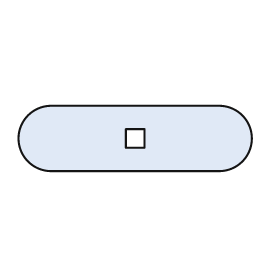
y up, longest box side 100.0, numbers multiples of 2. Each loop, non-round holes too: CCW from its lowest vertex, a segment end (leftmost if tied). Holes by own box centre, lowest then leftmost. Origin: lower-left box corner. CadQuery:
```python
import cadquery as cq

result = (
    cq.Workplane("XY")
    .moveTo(14.0, 0.0)
    .lineTo(86.0, 0.0)
    .threePointArc((100.0, 14.0), (86.0, 28.0))
    .lineTo(14.0, 28.0)
    .threePointArc((0.0, 14.0), (14.0, 0.0))
    .close()
    .moveTo(46.0, 10.0)
    .lineTo(54.0, 10.0)
    .lineTo(54.0, 18.0)
    .lineTo(46.0, 18.0)
    .close()
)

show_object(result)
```